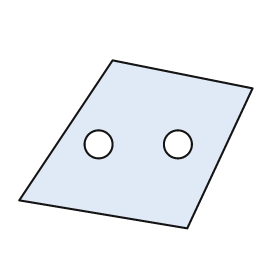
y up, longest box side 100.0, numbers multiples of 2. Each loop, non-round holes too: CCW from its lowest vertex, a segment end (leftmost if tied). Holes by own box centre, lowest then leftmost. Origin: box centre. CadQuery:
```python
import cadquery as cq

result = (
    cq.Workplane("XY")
    .moveTo(22.0, -36.0)
    .lineTo(50.0, 24.0)
    .lineTo(-10.0, 36.0)
    .lineTo(-50.0, -24.0)
    .close()
    .moveTo(-16.0, 0.0)
    .circle(6.0)
    .moveTo(18.0, 0.0)
    .circle(6.0)
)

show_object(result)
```